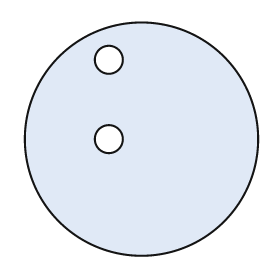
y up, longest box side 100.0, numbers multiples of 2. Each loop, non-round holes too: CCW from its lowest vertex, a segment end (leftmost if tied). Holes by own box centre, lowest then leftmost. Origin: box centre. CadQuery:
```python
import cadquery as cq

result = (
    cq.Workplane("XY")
    .moveTo(0.0, 0.0)
    .circle(50.0)
    .moveTo(-14.0, 0.0)
    .circle(6.0)
    .moveTo(-14.0, 34.0)
    .circle(6.0)
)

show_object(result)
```